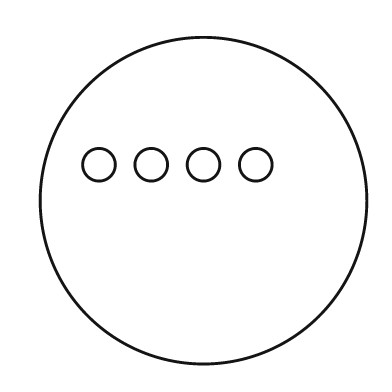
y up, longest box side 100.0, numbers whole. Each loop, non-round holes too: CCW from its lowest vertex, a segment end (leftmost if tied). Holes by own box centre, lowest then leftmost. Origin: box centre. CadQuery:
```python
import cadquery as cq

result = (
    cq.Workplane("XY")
    .moveTo(0.0, 0.0)
    .circle(50.0)
    .moveTo(-32.0, 11.0)
    .circle(5.0)
    .moveTo(-16.0, 11.0)
    .circle(5.0)
    .moveTo(0.0, 11.0)
    .circle(5.0)
    .moveTo(16.0, 11.0)
    .circle(5.0)
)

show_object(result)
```